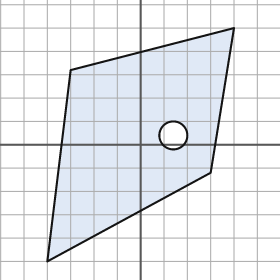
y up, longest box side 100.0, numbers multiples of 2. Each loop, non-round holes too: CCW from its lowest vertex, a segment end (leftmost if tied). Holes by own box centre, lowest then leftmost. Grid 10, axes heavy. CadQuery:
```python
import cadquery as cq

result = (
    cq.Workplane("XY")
    .moveTo(-40.0, -50.0)
    .lineTo(30.0, -12.0)
    .lineTo(40.0, 50.0)
    .lineTo(-30.0, 32.0)
    .close()
    .moveTo(14.0, 4.0)
    .circle(6.0)
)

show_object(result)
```